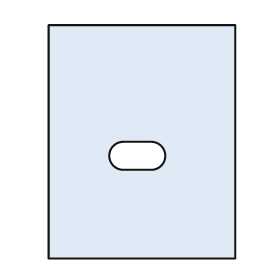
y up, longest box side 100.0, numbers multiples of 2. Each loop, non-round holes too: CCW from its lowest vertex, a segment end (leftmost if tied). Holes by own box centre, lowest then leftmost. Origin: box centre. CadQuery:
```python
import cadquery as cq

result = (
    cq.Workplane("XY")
    .moveTo(-40.0, -50.0)
    .lineTo(40.0, -50.0)
    .lineTo(40.0, 50.0)
    .lineTo(-40.0, 50.0)
    .close()
    .moveTo(-8.0, -12.0)
    .lineTo(4.0, -12.0)
    .threePointArc((10.0, -6.0), (4.0, 0.0))
    .lineTo(-8.0, 0.0)
    .threePointArc((-14.0, -6.0), (-8.0, -12.0))
    .close()
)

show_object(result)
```